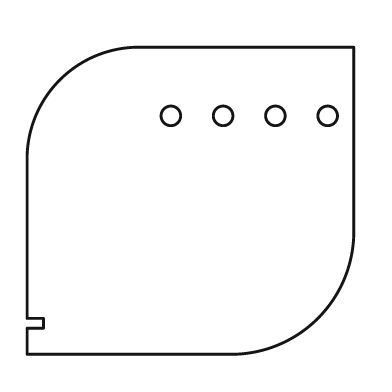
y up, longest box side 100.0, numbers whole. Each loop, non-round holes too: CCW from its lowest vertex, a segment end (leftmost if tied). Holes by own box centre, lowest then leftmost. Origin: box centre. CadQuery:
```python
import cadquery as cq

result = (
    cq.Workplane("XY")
    .moveTo(-50.0, -47.0)
    .lineTo(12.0, -47.0)
    .threePointArc((39.0, -36.0), (50.0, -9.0))
    .lineTo(50.0, 47.0)
    .lineTo(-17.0, 47.0)
    .threePointArc((-40.0, 37.0), (-50.0, 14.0))
    .lineTo(-50.0, -36.0)
    .lineTo(-45.0, -36.0)
    .lineTo(-45.0, -39.0)
    .lineTo(-50.0, -39.0)
    .close()
    .moveTo(-6.0, 26.0)
    .circle(3.0)
    .moveTo(10.0, 26.0)
    .circle(3.0)
    .moveTo(26.0, 26.0)
    .circle(3.0)
    .moveTo(42.0, 26.0)
    .circle(3.0)
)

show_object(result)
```